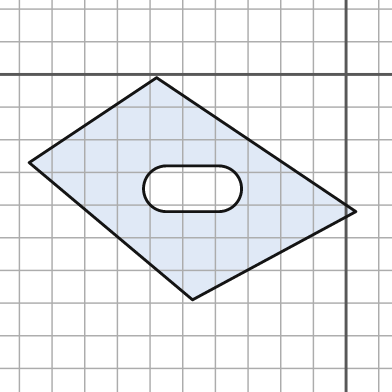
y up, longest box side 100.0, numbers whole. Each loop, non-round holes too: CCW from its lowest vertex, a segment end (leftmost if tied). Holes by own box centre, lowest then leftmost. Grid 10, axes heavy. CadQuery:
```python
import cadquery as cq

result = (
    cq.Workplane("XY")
    .moveTo(-47.0, -69.0)
    .lineTo(3.0, -42.0)
    .lineTo(-58.0, -1.0)
    .lineTo(-97.0, -27.0)
    .close()
    .moveTo(-55.0, -42.0)
    .lineTo(-39.0, -42.0)
    .threePointArc((-32.0, -35.0), (-39.0, -28.0))
    .lineTo(-55.0, -28.0)
    .threePointArc((-62.0, -35.0), (-55.0, -42.0))
    .close()
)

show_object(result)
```